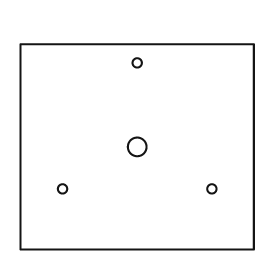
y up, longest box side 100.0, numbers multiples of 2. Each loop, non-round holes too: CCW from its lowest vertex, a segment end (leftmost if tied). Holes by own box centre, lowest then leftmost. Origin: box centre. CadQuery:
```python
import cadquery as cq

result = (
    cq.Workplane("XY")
    .moveTo(-50.0, -44.0)
    .lineTo(50.0, -44.0)
    .lineTo(50.0, 44.0)
    .lineTo(-50.0, 44.0)
    .close()
    .moveTo(-32.0, -18.0)
    .circle(2.0)
    .moveTo(32.0, -18.0)
    .circle(2.0)
    .moveTo(0.0, 0.0)
    .circle(4.0)
    .moveTo(0.0, 36.0)
    .circle(2.0)
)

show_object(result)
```